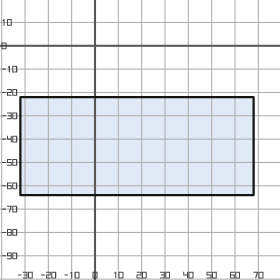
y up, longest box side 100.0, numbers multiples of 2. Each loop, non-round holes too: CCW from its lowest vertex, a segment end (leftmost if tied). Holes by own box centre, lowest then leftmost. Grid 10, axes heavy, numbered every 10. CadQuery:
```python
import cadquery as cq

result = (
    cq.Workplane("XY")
    .moveTo(-32.0, -64.0)
    .lineTo(68.0, -64.0)
    .lineTo(68.0, -22.0)
    .lineTo(-32.0, -22.0)
    .close()
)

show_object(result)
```